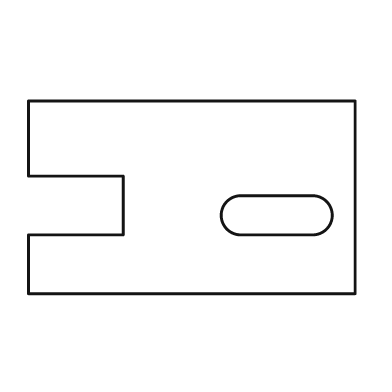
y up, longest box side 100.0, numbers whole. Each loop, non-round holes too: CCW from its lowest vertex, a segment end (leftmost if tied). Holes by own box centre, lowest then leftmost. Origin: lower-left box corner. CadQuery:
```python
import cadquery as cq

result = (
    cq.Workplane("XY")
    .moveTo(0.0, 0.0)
    .lineTo(100.0, 0.0)
    .lineTo(100.0, 59.0)
    .lineTo(0.0, 59.0)
    .lineTo(0.0, 36.0)
    .lineTo(29.0, 36.0)
    .lineTo(29.0, 18.0)
    .lineTo(0.0, 18.0)
    .close()
    .moveTo(65.0, 18.0)
    .lineTo(87.0, 18.0)
    .threePointArc((93.0, 24.0), (87.0, 30.0))
    .lineTo(65.0, 30.0)
    .threePointArc((59.0, 24.0), (65.0, 18.0))
    .close()
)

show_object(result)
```